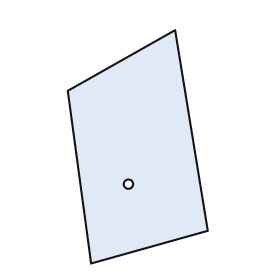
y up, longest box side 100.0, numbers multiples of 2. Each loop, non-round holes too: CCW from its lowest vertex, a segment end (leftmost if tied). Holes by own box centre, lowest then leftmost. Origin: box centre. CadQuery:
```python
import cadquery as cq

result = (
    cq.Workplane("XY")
    .moveTo(-20.0, -50.0)
    .lineTo(30.0, -36.0)
    .lineTo(16.0, 50.0)
    .lineTo(-30.0, 24.0)
    .close()
    .moveTo(-4.0, -16.0)
    .circle(2.0)
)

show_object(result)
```